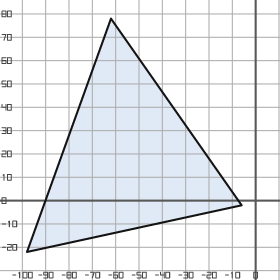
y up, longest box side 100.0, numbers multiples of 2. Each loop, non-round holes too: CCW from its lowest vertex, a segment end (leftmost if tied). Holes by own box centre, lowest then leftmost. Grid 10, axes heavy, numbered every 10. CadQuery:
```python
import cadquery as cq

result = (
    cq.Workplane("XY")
    .moveTo(-98.0, -22.0)
    .lineTo(-6.0, -2.0)
    .lineTo(-62.0, 78.0)
    .close()
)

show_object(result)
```